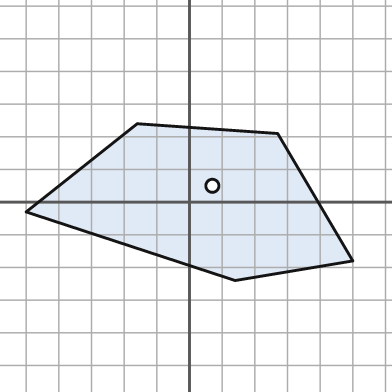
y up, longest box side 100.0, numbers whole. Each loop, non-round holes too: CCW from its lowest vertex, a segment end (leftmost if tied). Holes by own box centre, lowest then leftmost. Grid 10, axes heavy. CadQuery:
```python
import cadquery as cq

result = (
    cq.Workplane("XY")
    .moveTo(14.0, -24.0)
    .lineTo(50.0, -18.0)
    .lineTo(27.0, 21.0)
    .lineTo(-16.0, 24.0)
    .lineTo(-50.0, -3.0)
    .close()
    .moveTo(7.0, 5.0)
    .circle(2.0)
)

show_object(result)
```